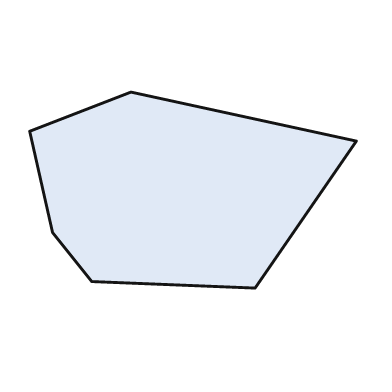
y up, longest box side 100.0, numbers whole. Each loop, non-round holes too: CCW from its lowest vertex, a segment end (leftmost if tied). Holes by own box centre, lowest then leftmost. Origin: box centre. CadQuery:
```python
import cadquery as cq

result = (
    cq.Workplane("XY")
    .moveTo(19.0, -30.0)
    .lineTo(50.0, 15.0)
    .lineTo(-19.0, 30.0)
    .lineTo(-50.0, 18.0)
    .lineTo(-43.0, -13.0)
    .lineTo(-31.0, -28.0)
    .close()
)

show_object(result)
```